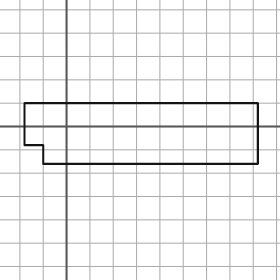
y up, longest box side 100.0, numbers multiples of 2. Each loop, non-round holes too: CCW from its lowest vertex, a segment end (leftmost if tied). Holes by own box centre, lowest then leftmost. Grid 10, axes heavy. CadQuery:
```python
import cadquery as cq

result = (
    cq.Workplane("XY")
    .moveTo(-10.0, -16.0)
    .lineTo(82.0, -16.0)
    .lineTo(82.0, 10.0)
    .lineTo(-18.0, 10.0)
    .lineTo(-18.0, -8.0)
    .lineTo(-10.0, -8.0)
    .close()
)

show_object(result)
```